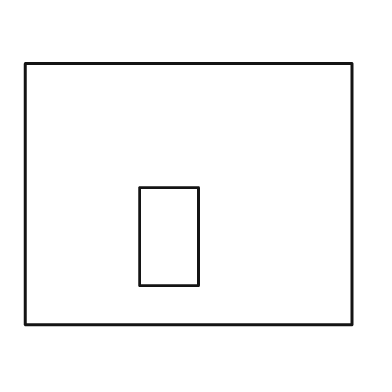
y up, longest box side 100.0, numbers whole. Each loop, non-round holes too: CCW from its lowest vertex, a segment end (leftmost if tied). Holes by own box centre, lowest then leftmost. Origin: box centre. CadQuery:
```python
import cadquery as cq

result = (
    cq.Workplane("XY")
    .moveTo(-50.0, -40.0)
    .lineTo(50.0, -40.0)
    .lineTo(50.0, 40.0)
    .lineTo(-50.0, 40.0)
    .close()
    .moveTo(-15.0, -28.0)
    .lineTo(3.0, -28.0)
    .lineTo(3.0, 2.0)
    .lineTo(-15.0, 2.0)
    .close()
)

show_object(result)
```